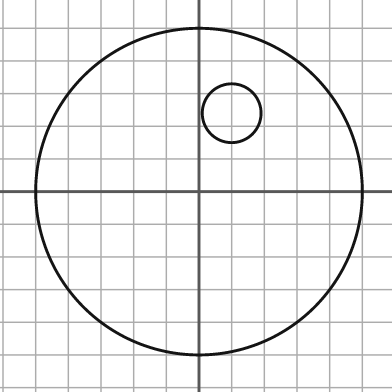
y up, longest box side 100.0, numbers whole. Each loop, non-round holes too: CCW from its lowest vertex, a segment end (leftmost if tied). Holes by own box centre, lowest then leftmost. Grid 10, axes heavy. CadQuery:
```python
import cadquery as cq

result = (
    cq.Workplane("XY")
    .moveTo(0.0, 0.0)
    .circle(50.0)
    .moveTo(10.0, 24.0)
    .circle(9.0)
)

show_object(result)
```